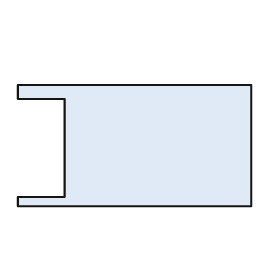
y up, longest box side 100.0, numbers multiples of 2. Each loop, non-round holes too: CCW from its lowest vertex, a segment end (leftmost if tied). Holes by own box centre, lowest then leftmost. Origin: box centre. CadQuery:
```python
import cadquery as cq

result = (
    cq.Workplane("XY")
    .moveTo(-50.0, -26.0)
    .lineTo(50.0, -26.0)
    .lineTo(50.0, 26.0)
    .lineTo(-50.0, 26.0)
    .lineTo(-50.0, 20.0)
    .lineTo(-30.0, 20.0)
    .lineTo(-30.0, -22.0)
    .lineTo(-50.0, -22.0)
    .close()
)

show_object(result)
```